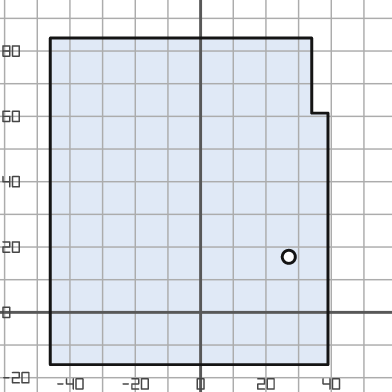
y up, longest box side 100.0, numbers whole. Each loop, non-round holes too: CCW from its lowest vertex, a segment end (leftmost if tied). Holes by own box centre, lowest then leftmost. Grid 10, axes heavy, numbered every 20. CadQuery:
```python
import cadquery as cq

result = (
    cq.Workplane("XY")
    .moveTo(-46.0, -16.0)
    .lineTo(39.0, -16.0)
    .lineTo(39.0, 61.0)
    .lineTo(34.0, 61.0)
    .lineTo(34.0, 84.0)
    .lineTo(-46.0, 84.0)
    .close()
    .moveTo(27.0, 17.0)
    .circle(2.0)
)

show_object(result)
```